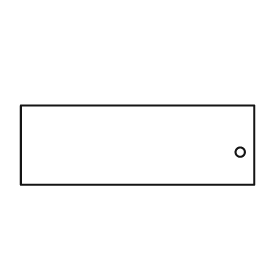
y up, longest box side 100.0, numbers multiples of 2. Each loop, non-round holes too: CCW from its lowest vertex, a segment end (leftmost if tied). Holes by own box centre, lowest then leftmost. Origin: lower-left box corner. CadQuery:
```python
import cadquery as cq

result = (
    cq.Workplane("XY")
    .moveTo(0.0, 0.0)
    .lineTo(100.0, 0.0)
    .lineTo(100.0, 34.0)
    .lineTo(0.0, 34.0)
    .close()
    .moveTo(94.0, 14.0)
    .circle(2.0)
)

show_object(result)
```